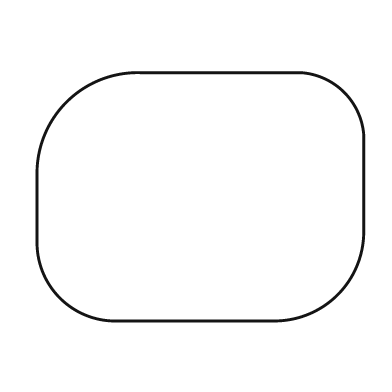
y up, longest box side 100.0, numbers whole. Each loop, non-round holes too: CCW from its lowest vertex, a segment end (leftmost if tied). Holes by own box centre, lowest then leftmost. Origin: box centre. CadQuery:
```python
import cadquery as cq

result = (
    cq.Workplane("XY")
    .moveTo(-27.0, -38.0)
    .lineTo(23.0, -38.0)
    .threePointArc((42.0, -30.0), (50.0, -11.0))
    .lineTo(50.0, 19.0)
    .threePointArc((44.0, 32.0), (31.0, 38.0))
    .lineTo(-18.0, 38.0)
    .threePointArc((-41.0, 29.0), (-50.0, 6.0))
    .lineTo(-50.0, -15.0)
    .threePointArc((-43.0, -31.0), (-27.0, -38.0))
    .close()
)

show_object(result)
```